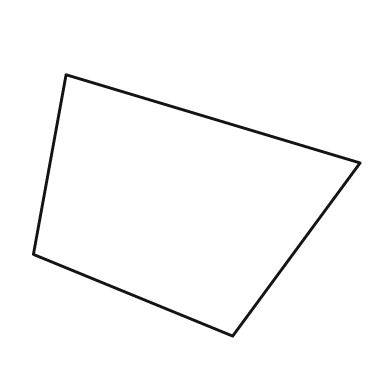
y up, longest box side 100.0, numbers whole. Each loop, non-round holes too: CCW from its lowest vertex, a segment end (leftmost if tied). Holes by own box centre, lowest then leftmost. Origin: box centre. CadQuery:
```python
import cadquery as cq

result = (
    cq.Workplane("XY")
    .moveTo(11.0, -40.0)
    .lineTo(50.0, 13.0)
    .lineTo(-40.0, 40.0)
    .lineTo(-50.0, -15.0)
    .close()
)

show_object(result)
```